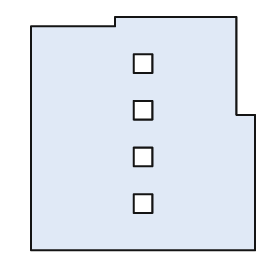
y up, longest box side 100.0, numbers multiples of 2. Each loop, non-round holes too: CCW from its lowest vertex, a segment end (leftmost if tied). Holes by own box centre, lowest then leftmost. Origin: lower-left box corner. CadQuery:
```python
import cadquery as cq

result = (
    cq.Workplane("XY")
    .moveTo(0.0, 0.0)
    .lineTo(96.0, 0.0)
    .lineTo(96.0, 58.0)
    .lineTo(88.0, 58.0)
    .lineTo(88.0, 100.0)
    .lineTo(36.0, 100.0)
    .lineTo(36.0, 96.0)
    .lineTo(0.0, 96.0)
    .close()
    .moveTo(44.0, 16.0)
    .lineTo(52.0, 16.0)
    .lineTo(52.0, 24.0)
    .lineTo(44.0, 24.0)
    .close()
    .moveTo(44.0, 36.0)
    .lineTo(52.0, 36.0)
    .lineTo(52.0, 44.0)
    .lineTo(44.0, 44.0)
    .close()
    .moveTo(44.0, 56.0)
    .lineTo(52.0, 56.0)
    .lineTo(52.0, 64.0)
    .lineTo(44.0, 64.0)
    .close()
    .moveTo(44.0, 76.0)
    .lineTo(52.0, 76.0)
    .lineTo(52.0, 84.0)
    .lineTo(44.0, 84.0)
    .close()
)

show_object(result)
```